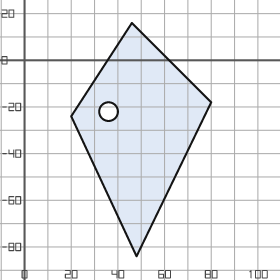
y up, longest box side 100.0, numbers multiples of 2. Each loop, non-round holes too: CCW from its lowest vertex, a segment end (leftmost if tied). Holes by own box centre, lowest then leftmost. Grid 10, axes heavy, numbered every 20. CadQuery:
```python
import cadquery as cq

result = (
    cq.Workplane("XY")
    .moveTo(48.0, -84.0)
    .lineTo(80.0, -18.0)
    .lineTo(46.0, 16.0)
    .lineTo(20.0, -24.0)
    .close()
    .moveTo(36.0, -22.0)
    .circle(4.0)
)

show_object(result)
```